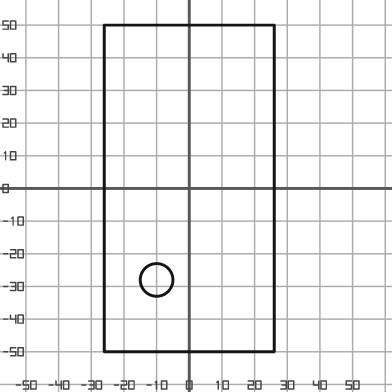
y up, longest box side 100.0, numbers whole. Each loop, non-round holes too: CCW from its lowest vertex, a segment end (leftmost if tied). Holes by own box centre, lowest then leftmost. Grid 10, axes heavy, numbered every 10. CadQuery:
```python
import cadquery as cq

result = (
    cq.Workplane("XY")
    .moveTo(-26.0, -50.0)
    .lineTo(26.0, -50.0)
    .lineTo(26.0, 50.0)
    .lineTo(-26.0, 50.0)
    .close()
    .moveTo(-10.0, -28.0)
    .circle(5.0)
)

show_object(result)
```